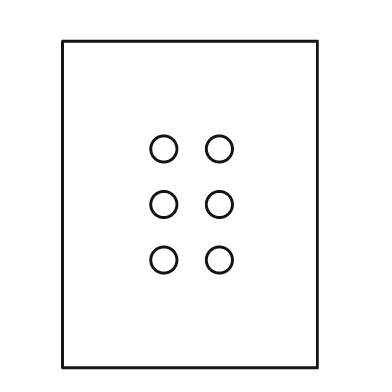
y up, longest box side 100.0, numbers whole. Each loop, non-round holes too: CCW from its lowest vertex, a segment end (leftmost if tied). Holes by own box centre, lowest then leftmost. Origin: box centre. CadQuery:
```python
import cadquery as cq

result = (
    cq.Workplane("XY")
    .moveTo(-39.0, -50.0)
    .lineTo(39.0, -50.0)
    .lineTo(39.0, 50.0)
    .lineTo(-39.0, 50.0)
    .close()
    .moveTo(-8.0, -17.0)
    .circle(4.0)
    .moveTo(9.0, -17.0)
    .circle(4.0)
    .moveTo(-8.0, 0.0)
    .circle(4.0)
    .moveTo(9.0, 0.0)
    .circle(4.0)
    .moveTo(-8.0, 17.0)
    .circle(4.0)
    .moveTo(9.0, 17.0)
    .circle(4.0)
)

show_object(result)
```